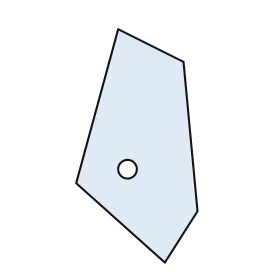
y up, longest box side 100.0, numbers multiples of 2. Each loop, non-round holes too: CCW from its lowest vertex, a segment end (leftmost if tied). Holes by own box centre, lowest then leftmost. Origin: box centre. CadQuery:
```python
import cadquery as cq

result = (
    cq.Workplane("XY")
    .moveTo(12.0, -50.0)
    .lineTo(26.0, -28.0)
    .lineTo(20.0, 36.0)
    .lineTo(-8.0, 50.0)
    .lineTo(-26.0, -16.0)
    .close()
    .moveTo(-4.0, -10.0)
    .circle(4.0)
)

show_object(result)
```